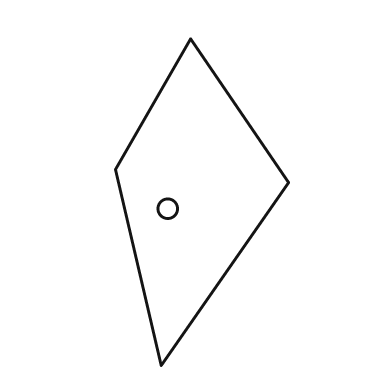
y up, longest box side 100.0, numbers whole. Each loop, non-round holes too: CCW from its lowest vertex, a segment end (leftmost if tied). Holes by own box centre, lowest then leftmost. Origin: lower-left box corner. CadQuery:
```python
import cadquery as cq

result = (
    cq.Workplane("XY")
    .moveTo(14.0, 0.0)
    .lineTo(53.0, 56.0)
    .lineTo(23.0, 100.0)
    .lineTo(0.0, 60.0)
    .close()
    .moveTo(16.0, 48.0)
    .circle(3.0)
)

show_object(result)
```